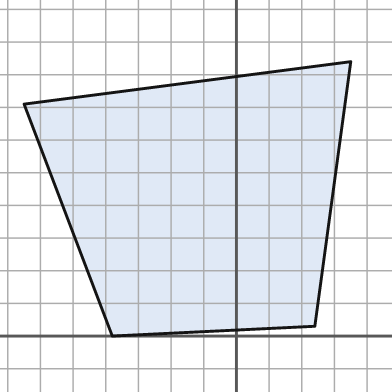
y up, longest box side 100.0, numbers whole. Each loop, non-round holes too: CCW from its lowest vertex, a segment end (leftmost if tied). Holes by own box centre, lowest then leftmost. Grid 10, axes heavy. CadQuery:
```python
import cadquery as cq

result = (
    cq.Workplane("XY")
    .moveTo(-38.0, 0.0)
    .lineTo(24.0, 3.0)
    .lineTo(35.0, 84.0)
    .lineTo(-65.0, 71.0)
    .close()
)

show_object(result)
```